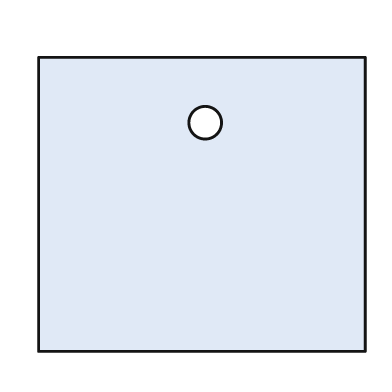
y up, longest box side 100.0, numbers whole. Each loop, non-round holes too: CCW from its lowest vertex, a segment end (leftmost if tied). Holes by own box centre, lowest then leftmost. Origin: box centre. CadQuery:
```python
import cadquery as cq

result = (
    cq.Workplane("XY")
    .moveTo(-50.0, -45.0)
    .lineTo(50.0, -45.0)
    .lineTo(50.0, 45.0)
    .lineTo(-50.0, 45.0)
    .close()
    .moveTo(1.0, 25.0)
    .circle(5.0)
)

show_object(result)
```